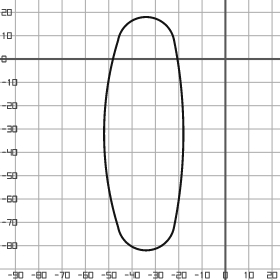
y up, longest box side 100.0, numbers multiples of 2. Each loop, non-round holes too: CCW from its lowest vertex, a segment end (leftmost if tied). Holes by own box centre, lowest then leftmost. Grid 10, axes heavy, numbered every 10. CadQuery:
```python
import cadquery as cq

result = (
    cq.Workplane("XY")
    .moveTo(-46.0, -72.0)
    .threePointArc((-34.0, -82.0), (-22.0, -72.0))
    .threePointArc((-18.0, -32.0), (-22.0, 8.0))
    .threePointArc((-34.0, 18.0), (-46.0, 8.0))
    .threePointArc((-52.0, -32.0), (-46.0, -72.0))
    .close()
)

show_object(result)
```